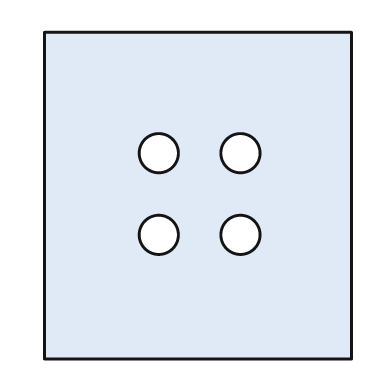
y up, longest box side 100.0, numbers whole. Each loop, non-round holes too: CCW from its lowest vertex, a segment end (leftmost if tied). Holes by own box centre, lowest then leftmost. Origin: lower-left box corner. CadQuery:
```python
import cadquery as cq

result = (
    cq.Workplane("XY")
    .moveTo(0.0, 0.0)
    .lineTo(94.0, 0.0)
    .lineTo(94.0, 100.0)
    .lineTo(0.0, 100.0)
    .close()
    .moveTo(35.0, 38.0)
    .circle(6.0)
    .moveTo(60.0, 38.0)
    .circle(6.0)
    .moveTo(35.0, 63.0)
    .circle(6.0)
    .moveTo(60.0, 63.0)
    .circle(6.0)
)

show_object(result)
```